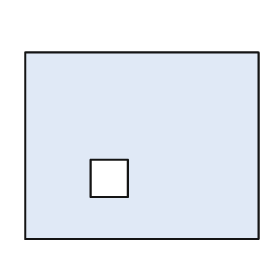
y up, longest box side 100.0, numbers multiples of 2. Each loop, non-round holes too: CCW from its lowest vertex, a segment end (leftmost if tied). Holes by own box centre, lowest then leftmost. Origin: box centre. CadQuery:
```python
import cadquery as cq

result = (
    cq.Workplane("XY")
    .moveTo(-50.0, -40.0)
    .lineTo(50.0, -40.0)
    .lineTo(50.0, 40.0)
    .lineTo(-50.0, 40.0)
    .close()
    .moveTo(-22.0, -22.0)
    .lineTo(-6.0, -22.0)
    .lineTo(-6.0, -6.0)
    .lineTo(-22.0, -6.0)
    .close()
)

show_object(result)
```